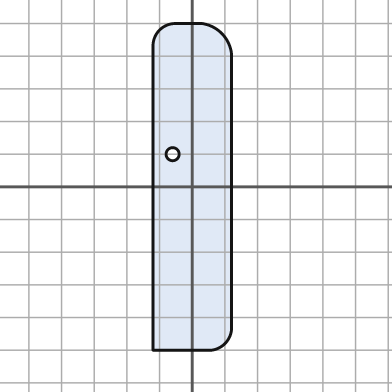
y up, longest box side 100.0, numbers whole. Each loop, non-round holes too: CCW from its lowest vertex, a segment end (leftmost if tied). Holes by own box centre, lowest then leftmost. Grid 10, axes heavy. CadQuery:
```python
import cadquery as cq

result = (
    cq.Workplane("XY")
    .moveTo(-12.0, -50.0)
    .lineTo(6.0, -50.0)
    .threePointArc((10.0, -48.0), (12.0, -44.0))
    .lineTo(12.0, 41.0)
    .threePointArc((9.0, 47.0), (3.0, 50.0))
    .lineTo(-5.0, 50.0)
    .threePointArc((-10.0, 48.0), (-12.0, 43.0))
    .close()
    .moveTo(-6.0, 10.0)
    .circle(2.0)
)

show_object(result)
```